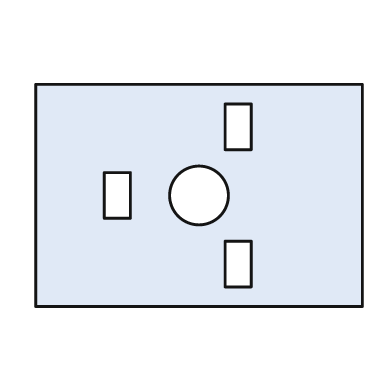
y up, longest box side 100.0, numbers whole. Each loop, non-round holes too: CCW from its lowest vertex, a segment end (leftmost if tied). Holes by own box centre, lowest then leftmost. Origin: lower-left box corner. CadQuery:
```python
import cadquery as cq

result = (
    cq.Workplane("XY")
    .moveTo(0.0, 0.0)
    .lineTo(100.0, 0.0)
    .lineTo(100.0, 68.0)
    .lineTo(0.0, 68.0)
    .close()
    .moveTo(58.0, 6.0)
    .lineTo(66.0, 6.0)
    .lineTo(66.0, 20.0)
    .lineTo(58.0, 20.0)
    .close()
    .moveTo(21.0, 27.0)
    .lineTo(29.0, 27.0)
    .lineTo(29.0, 41.0)
    .lineTo(21.0, 41.0)
    .close()
    .moveTo(50.0, 34.0)
    .circle(9.0)
    .moveTo(58.0, 48.0)
    .lineTo(66.0, 48.0)
    .lineTo(66.0, 62.0)
    .lineTo(58.0, 62.0)
    .close()
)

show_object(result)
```